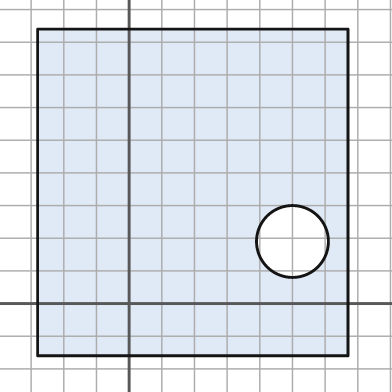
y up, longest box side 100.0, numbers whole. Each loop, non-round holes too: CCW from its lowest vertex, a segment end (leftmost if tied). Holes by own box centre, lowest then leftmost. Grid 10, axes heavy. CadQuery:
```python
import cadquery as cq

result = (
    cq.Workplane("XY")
    .moveTo(-28.0, -16.0)
    .lineTo(67.0, -16.0)
    .lineTo(67.0, 84.0)
    .lineTo(-28.0, 84.0)
    .close()
    .moveTo(50.0, 19.0)
    .circle(11.0)
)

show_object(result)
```